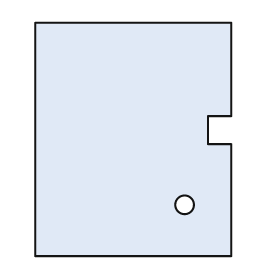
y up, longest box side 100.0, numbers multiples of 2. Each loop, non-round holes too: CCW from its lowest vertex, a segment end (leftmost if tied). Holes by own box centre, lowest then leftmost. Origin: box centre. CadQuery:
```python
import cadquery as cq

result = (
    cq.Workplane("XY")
    .moveTo(-42.0, -50.0)
    .lineTo(42.0, -50.0)
    .lineTo(42.0, -2.0)
    .lineTo(32.0, -2.0)
    .lineTo(32.0, 10.0)
    .lineTo(42.0, 10.0)
    .lineTo(42.0, 50.0)
    .lineTo(-42.0, 50.0)
    .close()
    .moveTo(22.0, -28.0)
    .circle(4.0)
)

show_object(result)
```